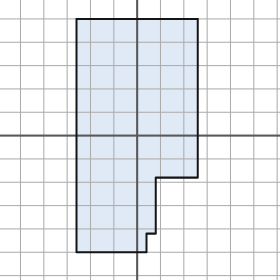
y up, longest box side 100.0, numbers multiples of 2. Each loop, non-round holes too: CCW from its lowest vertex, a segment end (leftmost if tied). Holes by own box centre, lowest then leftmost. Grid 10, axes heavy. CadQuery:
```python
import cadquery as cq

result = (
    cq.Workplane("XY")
    .moveTo(-26.0, -50.0)
    .lineTo(4.0, -50.0)
    .lineTo(4.0, -42.0)
    .lineTo(8.0, -42.0)
    .lineTo(8.0, -18.0)
    .lineTo(26.0, -18.0)
    .lineTo(26.0, 50.0)
    .lineTo(-26.0, 50.0)
    .close()
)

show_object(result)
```